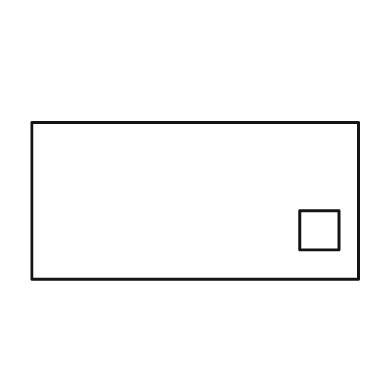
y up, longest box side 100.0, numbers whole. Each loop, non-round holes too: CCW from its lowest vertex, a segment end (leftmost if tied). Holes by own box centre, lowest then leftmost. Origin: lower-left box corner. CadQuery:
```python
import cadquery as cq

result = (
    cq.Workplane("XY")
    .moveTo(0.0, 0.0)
    .lineTo(100.0, 0.0)
    .lineTo(100.0, 48.0)
    .lineTo(0.0, 48.0)
    .close()
    .moveTo(82.0, 9.0)
    .lineTo(94.0, 9.0)
    .lineTo(94.0, 21.0)
    .lineTo(82.0, 21.0)
    .close()
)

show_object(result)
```